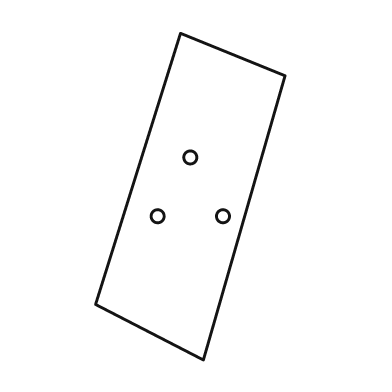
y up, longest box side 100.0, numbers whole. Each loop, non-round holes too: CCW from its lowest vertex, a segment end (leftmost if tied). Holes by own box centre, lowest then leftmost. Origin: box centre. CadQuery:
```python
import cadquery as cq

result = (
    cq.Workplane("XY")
    .moveTo(4.0, -50.0)
    .lineTo(29.0, 37.0)
    .lineTo(-3.0, 50.0)
    .lineTo(-29.0, -33.0)
    .close()
    .moveTo(-10.0, -6.0)
    .circle(2.0)
    .moveTo(10.0, -6.0)
    .circle(2.0)
    .moveTo(0.0, 12.0)
    .circle(2.0)
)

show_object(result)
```